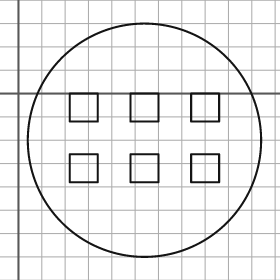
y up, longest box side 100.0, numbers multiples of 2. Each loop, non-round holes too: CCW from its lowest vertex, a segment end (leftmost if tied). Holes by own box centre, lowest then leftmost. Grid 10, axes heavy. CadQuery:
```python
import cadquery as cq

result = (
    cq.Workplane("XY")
    .moveTo(54.0, -20.0)
    .circle(50.0)
    .moveTo(22.0, -38.0)
    .lineTo(34.0, -38.0)
    .lineTo(34.0, -26.0)
    .lineTo(22.0, -26.0)
    .close()
    .moveTo(48.0, -38.0)
    .lineTo(60.0, -38.0)
    .lineTo(60.0, -26.0)
    .lineTo(48.0, -26.0)
    .close()
    .moveTo(74.0, -38.0)
    .lineTo(86.0, -38.0)
    .lineTo(86.0, -26.0)
    .lineTo(74.0, -26.0)
    .close()
    .moveTo(22.0, -12.0)
    .lineTo(34.0, -12.0)
    .lineTo(34.0, 0.0)
    .lineTo(22.0, 0.0)
    .close()
    .moveTo(48.0, -12.0)
    .lineTo(60.0, -12.0)
    .lineTo(60.0, 0.0)
    .lineTo(48.0, 0.0)
    .close()
    .moveTo(74.0, -12.0)
    .lineTo(86.0, -12.0)
    .lineTo(86.0, 0.0)
    .lineTo(74.0, 0.0)
    .close()
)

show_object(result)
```